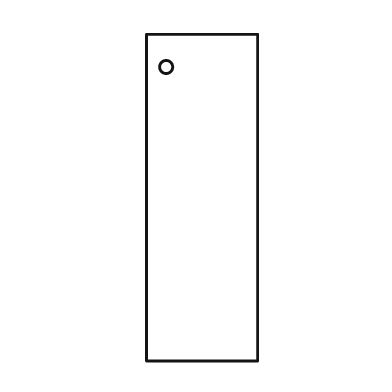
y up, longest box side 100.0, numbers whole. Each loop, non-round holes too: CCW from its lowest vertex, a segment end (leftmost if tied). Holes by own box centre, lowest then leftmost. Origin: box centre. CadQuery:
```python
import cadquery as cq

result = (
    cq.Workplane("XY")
    .moveTo(-17.0, -50.0)
    .lineTo(17.0, -50.0)
    .lineTo(17.0, 50.0)
    .lineTo(-17.0, 50.0)
    .close()
    .moveTo(-11.0, 40.0)
    .circle(2.0)
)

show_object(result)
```